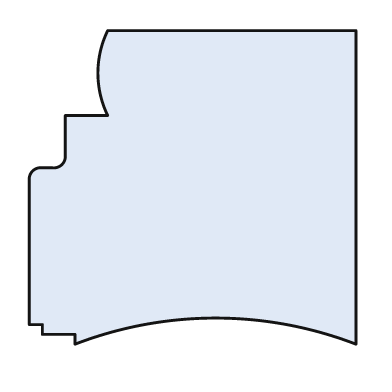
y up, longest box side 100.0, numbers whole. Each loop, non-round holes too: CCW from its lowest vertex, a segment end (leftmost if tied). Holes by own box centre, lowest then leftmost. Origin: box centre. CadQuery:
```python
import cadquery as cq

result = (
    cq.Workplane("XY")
    .moveTo(-36.0, -48.0)
    .threePointArc((7.0, -40.0), (50.0, -48.0))
    .lineTo(50.0, 48.0)
    .lineTo(-26.0, 48.0)
    .threePointArc((-29.0, 35.0), (-26.0, 22.0))
    .lineTo(-39.0, 22.0)
    .lineTo(-39.0, 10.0)
    .threePointArc((-40.0, 7.0), (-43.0, 6.0))
    .lineTo(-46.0, 6.0)
    .threePointArc((-49.0, 5.0), (-50.0, 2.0))
    .lineTo(-50.0, -42.0)
    .lineTo(-46.0, -42.0)
    .lineTo(-46.0, -45.0)
    .lineTo(-36.0, -45.0)
    .close()
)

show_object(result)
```